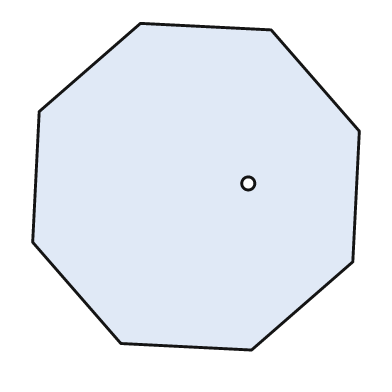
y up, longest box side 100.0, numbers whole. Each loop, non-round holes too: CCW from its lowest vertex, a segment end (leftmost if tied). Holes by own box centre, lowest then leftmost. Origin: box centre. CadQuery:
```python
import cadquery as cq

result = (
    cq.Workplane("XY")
    .moveTo(17.0, -50.0)
    .lineTo(48.0, -23.0)
    .lineTo(50.0, 17.0)
    .lineTo(23.0, 48.0)
    .lineTo(-17.0, 50.0)
    .lineTo(-48.0, 23.0)
    .lineTo(-50.0, -17.0)
    .lineTo(-23.0, -48.0)
    .close()
    .moveTo(16.0, 1.0)
    .circle(2.0)
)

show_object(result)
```